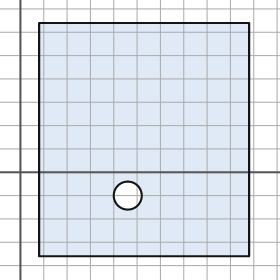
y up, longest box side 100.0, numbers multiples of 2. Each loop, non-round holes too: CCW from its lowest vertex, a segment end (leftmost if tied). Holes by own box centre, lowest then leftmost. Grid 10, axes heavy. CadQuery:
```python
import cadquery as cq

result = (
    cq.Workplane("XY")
    .moveTo(8.0, -36.0)
    .lineTo(98.0, -36.0)
    .lineTo(98.0, 64.0)
    .lineTo(8.0, 64.0)
    .close()
    .moveTo(46.0, -10.0)
    .circle(6.0)
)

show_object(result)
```